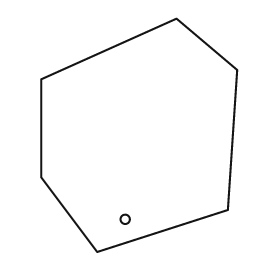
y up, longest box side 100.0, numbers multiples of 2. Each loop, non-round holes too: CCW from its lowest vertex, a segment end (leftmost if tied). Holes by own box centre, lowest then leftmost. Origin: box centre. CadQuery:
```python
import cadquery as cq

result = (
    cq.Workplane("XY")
    .moveTo(-18.0, -50.0)
    .lineTo(38.0, -32.0)
    .lineTo(42.0, 28.0)
    .lineTo(16.0, 50.0)
    .lineTo(-42.0, 24.0)
    .lineTo(-42.0, -18.0)
    .close()
    .moveTo(-6.0, -36.0)
    .circle(2.0)
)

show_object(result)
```